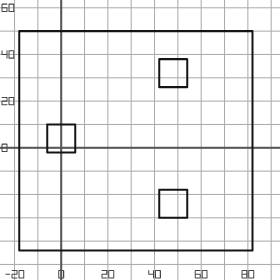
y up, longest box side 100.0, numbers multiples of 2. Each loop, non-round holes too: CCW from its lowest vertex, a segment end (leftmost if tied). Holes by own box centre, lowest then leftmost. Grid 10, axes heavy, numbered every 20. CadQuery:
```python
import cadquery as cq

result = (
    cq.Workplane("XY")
    .moveTo(-18.0, -44.0)
    .lineTo(82.0, -44.0)
    .lineTo(82.0, 50.0)
    .lineTo(-18.0, 50.0)
    .close()
    .moveTo(42.0, -30.0)
    .lineTo(54.0, -30.0)
    .lineTo(54.0, -18.0)
    .lineTo(42.0, -18.0)
    .close()
    .moveTo(-6.0, -2.0)
    .lineTo(6.0, -2.0)
    .lineTo(6.0, 10.0)
    .lineTo(-6.0, 10.0)
    .close()
    .moveTo(42.0, 26.0)
    .lineTo(54.0, 26.0)
    .lineTo(54.0, 38.0)
    .lineTo(42.0, 38.0)
    .close()
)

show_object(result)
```